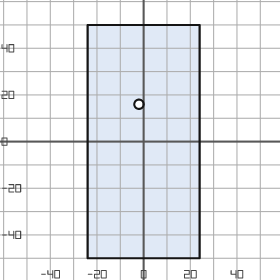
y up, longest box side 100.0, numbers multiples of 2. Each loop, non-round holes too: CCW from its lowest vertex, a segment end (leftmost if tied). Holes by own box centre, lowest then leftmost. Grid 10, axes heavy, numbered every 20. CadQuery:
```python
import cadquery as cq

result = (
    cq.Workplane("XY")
    .moveTo(-24.0, -50.0)
    .lineTo(24.0, -50.0)
    .lineTo(24.0, 50.0)
    .lineTo(-24.0, 50.0)
    .close()
    .moveTo(-2.0, 16.0)
    .circle(2.0)
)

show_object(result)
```